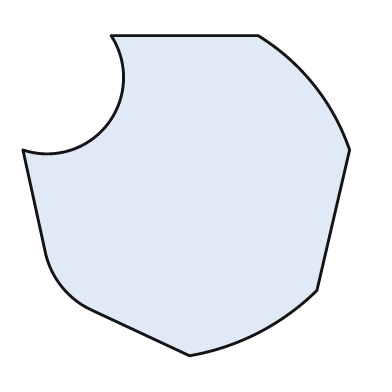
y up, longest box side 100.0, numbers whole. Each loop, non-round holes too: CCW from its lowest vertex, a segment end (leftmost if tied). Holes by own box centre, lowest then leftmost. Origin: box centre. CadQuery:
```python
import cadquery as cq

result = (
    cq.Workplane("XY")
    .moveTo(1.0, -49.0)
    .threePointArc((22.0, -42.0), (40.0, -29.0))
    .lineTo(50.0, 14.0)
    .threePointArc((39.0, 34.0), (22.0, 49.0))
    .lineTo(-23.0, 49.0)
    .threePointArc((-24.0, 22.0), (-50.0, 14.0))
    .lineTo(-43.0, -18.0)
    .threePointArc((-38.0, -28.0), (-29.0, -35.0))
    .close()
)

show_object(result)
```